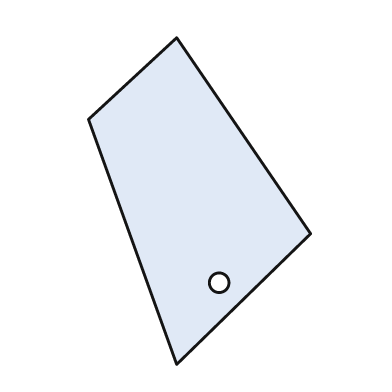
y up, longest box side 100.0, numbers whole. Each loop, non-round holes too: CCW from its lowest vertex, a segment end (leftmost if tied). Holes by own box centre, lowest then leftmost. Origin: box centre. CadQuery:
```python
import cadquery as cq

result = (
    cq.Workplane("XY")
    .moveTo(-7.0, -50.0)
    .lineTo(34.0, -10.0)
    .lineTo(-7.0, 50.0)
    .lineTo(-34.0, 25.0)
    .close()
    .moveTo(6.0, -25.0)
    .circle(3.0)
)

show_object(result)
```